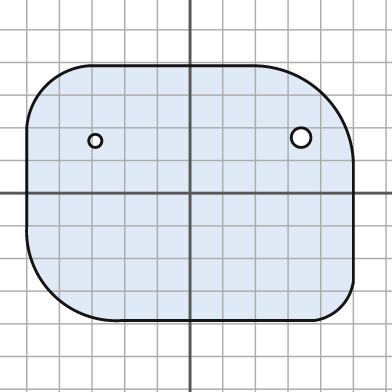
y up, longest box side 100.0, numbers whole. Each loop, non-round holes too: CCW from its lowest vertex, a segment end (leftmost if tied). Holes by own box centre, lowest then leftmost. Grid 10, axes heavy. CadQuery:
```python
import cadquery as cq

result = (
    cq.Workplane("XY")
    .moveTo(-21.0, -39.0)
    .lineTo(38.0, -39.0)
    .threePointArc((46.0, -35.0), (50.0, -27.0))
    .lineTo(50.0, 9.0)
    .threePointArc((41.0, 30.0), (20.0, 39.0))
    .lineTo(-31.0, 39.0)
    .threePointArc((-44.0, 33.0), (-50.0, 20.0))
    .lineTo(-50.0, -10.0)
    .threePointArc((-42.0, -31.0), (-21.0, -39.0))
    .close()
    .moveTo(-29.0, 16.0)
    .circle(2.0)
    .moveTo(34.0, 17.0)
    .circle(3.0)
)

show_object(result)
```